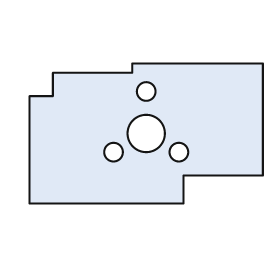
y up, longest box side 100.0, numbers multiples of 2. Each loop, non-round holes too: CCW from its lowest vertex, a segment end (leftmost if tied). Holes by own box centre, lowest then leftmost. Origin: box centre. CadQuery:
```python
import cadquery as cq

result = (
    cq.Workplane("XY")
    .moveTo(-50.0, -30.0)
    .lineTo(16.0, -30.0)
    .lineTo(16.0, -18.0)
    .lineTo(50.0, -18.0)
    .lineTo(50.0, 30.0)
    .lineTo(-6.0, 30.0)
    .lineTo(-6.0, 26.0)
    .lineTo(-40.0, 26.0)
    .lineTo(-40.0, 16.0)
    .lineTo(-50.0, 16.0)
    .close()
    .moveTo(-14.0, -8.0)
    .circle(4.0)
    .moveTo(14.0, -8.0)
    .circle(4.0)
    .moveTo(0.0, 0.0)
    .circle(8.0)
    .moveTo(0.0, 18.0)
    .circle(4.0)
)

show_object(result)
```